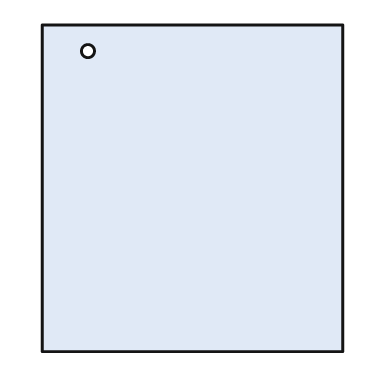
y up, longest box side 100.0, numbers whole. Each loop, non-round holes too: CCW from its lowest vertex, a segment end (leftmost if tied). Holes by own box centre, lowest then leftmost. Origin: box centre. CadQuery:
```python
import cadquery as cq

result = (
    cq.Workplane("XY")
    .moveTo(-46.0, -50.0)
    .lineTo(46.0, -50.0)
    .lineTo(46.0, 50.0)
    .lineTo(-46.0, 50.0)
    .close()
    .moveTo(-32.0, 42.0)
    .circle(2.0)
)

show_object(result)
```